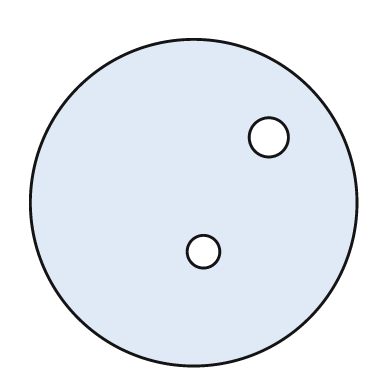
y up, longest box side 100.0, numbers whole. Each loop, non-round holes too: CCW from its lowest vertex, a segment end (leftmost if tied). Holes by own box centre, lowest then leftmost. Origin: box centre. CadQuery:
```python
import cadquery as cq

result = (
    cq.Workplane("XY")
    .moveTo(0.0, 0.0)
    .circle(50.0)
    .moveTo(3.0, -15.0)
    .circle(5.0)
    .moveTo(23.0, 20.0)
    .circle(6.0)
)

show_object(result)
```